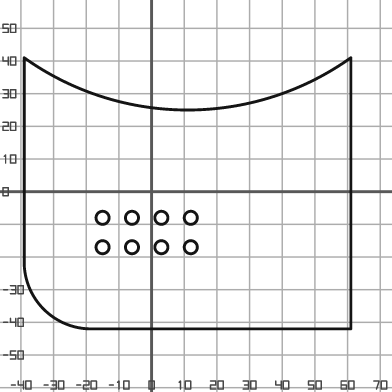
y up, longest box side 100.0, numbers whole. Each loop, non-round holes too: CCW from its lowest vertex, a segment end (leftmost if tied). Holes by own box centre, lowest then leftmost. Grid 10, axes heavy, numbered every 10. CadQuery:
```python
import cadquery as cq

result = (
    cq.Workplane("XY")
    .moveTo(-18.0, -42.0)
    .lineTo(61.0, -42.0)
    .lineTo(61.0, 41.0)
    .threePointArc((11.0, 25.0), (-39.0, 41.0))
    .lineTo(-39.0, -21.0)
    .threePointArc((-33.0, -36.0), (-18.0, -42.0))
    .close()
    .moveTo(-15.0, -17.0)
    .circle(2.0)
    .moveTo(-6.0, -17.0)
    .circle(2.0)
    .moveTo(3.0, -17.0)
    .circle(2.0)
    .moveTo(12.0, -17.0)
    .circle(2.0)
    .moveTo(-15.0, -8.0)
    .circle(2.0)
    .moveTo(-6.0, -8.0)
    .circle(2.0)
    .moveTo(3.0, -8.0)
    .circle(2.0)
    .moveTo(12.0, -8.0)
    .circle(2.0)
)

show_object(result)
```